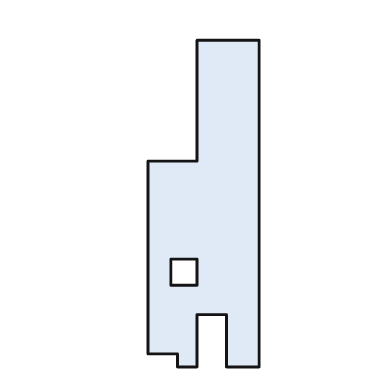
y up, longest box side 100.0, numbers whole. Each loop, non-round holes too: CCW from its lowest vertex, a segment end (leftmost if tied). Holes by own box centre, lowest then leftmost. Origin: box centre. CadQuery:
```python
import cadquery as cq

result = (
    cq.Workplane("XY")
    .moveTo(-8.0, -50.0)
    .lineTo(-2.0, -50.0)
    .lineTo(-2.0, -34.0)
    .lineTo(7.0, -34.0)
    .lineTo(7.0, -50.0)
    .lineTo(17.0, -50.0)
    .lineTo(17.0, 50.0)
    .lineTo(-2.0, 50.0)
    .lineTo(-2.0, 13.0)
    .lineTo(-17.0, 13.0)
    .lineTo(-17.0, -46.0)
    .lineTo(-8.0, -46.0)
    .close()
    .moveTo(-10.0, -25.0)
    .lineTo(-2.0, -25.0)
    .lineTo(-2.0, -17.0)
    .lineTo(-10.0, -17.0)
    .close()
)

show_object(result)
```